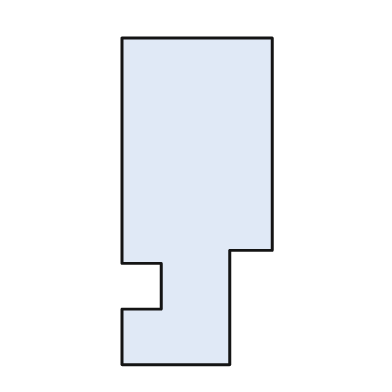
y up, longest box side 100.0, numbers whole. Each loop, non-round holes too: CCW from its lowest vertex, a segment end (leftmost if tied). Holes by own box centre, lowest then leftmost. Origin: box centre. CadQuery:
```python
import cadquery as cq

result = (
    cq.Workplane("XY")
    .moveTo(-23.0, -50.0)
    .lineTo(10.0, -50.0)
    .lineTo(10.0, -15.0)
    .lineTo(23.0, -15.0)
    .lineTo(23.0, 50.0)
    .lineTo(-23.0, 50.0)
    .lineTo(-23.0, -19.0)
    .lineTo(-11.0, -19.0)
    .lineTo(-11.0, -33.0)
    .lineTo(-23.0, -33.0)
    .close()
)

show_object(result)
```